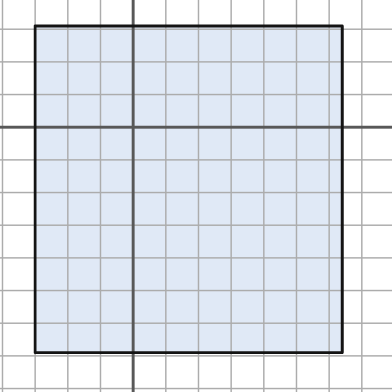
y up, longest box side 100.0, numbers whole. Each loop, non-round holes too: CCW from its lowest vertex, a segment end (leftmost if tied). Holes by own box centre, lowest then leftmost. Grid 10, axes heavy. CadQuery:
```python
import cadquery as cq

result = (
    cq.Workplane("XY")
    .moveTo(-30.0, -69.0)
    .lineTo(64.0, -69.0)
    .lineTo(64.0, 31.0)
    .lineTo(-30.0, 31.0)
    .close()
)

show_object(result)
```